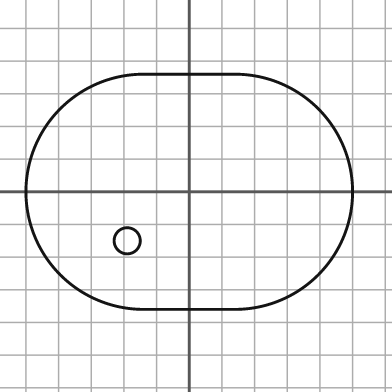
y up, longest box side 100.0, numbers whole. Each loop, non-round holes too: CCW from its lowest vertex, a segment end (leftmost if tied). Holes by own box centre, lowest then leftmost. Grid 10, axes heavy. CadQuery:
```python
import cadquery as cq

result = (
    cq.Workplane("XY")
    .moveTo(-14.0, -36.0)
    .lineTo(14.0, -36.0)
    .threePointArc((50.0, 0.0), (14.0, 36.0))
    .lineTo(-14.0, 36.0)
    .threePointArc((-50.0, 0.0), (-14.0, -36.0))
    .close()
    .moveTo(-19.0, -15.0)
    .circle(4.0)
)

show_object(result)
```